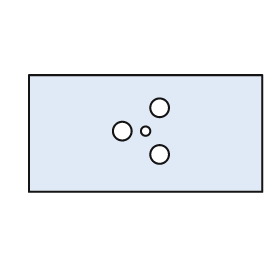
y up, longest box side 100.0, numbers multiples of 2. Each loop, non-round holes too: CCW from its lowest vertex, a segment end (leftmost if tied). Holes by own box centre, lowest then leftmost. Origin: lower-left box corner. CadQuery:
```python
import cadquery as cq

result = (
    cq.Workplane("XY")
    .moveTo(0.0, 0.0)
    .lineTo(100.0, 0.0)
    .lineTo(100.0, 50.0)
    .lineTo(0.0, 50.0)
    .close()
    .moveTo(56.0, 16.0)
    .circle(4.0)
    .moveTo(40.0, 26.0)
    .circle(4.0)
    .moveTo(50.0, 26.0)
    .circle(2.0)
    .moveTo(56.0, 36.0)
    .circle(4.0)
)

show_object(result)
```